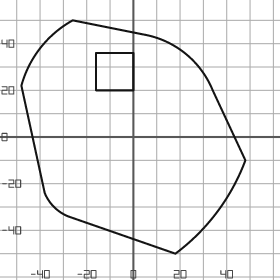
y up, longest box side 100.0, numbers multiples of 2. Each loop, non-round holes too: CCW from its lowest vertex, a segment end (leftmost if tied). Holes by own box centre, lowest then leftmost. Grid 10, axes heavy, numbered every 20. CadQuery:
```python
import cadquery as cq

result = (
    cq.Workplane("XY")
    .moveTo(18.0, -50.0)
    .threePointArc((36.0, -32.0), (48.0, -10.0))
    .lineTo(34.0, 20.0)
    .threePointArc((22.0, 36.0), (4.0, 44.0))
    .lineTo(-26.0, 50.0)
    .threePointArc((-40.0, 38.0), (-48.0, 22.0))
    .lineTo(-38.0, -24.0)
    .threePointArc((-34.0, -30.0), (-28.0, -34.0))
    .close()
    .moveTo(-16.0, 20.0)
    .lineTo(0.0, 20.0)
    .lineTo(0.0, 36.0)
    .lineTo(-16.0, 36.0)
    .close()
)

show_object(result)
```